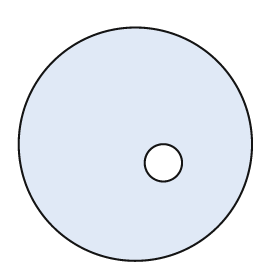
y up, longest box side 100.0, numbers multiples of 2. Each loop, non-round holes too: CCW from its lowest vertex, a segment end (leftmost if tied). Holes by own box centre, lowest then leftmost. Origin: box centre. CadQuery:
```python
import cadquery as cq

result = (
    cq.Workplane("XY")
    .moveTo(0.0, 0.0)
    .circle(50.0)
    .moveTo(12.0, -8.0)
    .circle(8.0)
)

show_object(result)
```